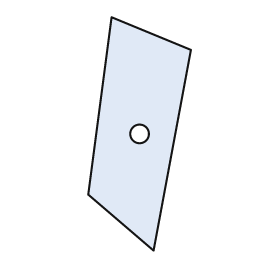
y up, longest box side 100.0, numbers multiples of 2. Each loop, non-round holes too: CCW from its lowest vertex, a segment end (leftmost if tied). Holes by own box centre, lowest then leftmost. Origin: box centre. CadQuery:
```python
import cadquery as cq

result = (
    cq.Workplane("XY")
    .moveTo(6.0, -50.0)
    .lineTo(22.0, 36.0)
    .lineTo(-12.0, 50.0)
    .lineTo(-22.0, -26.0)
    .close()
    .moveTo(0.0, 0.0)
    .circle(4.0)
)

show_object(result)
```